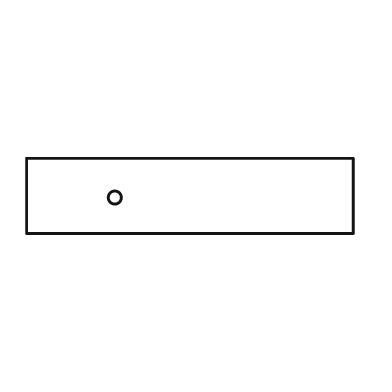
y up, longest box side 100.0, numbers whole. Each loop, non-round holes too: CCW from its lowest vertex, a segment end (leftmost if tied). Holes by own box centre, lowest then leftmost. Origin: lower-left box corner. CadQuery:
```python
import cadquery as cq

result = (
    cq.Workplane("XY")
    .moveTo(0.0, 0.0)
    .lineTo(100.0, 0.0)
    .lineTo(100.0, 23.0)
    .lineTo(0.0, 23.0)
    .close()
    .moveTo(27.0, 11.0)
    .circle(2.0)
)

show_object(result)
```